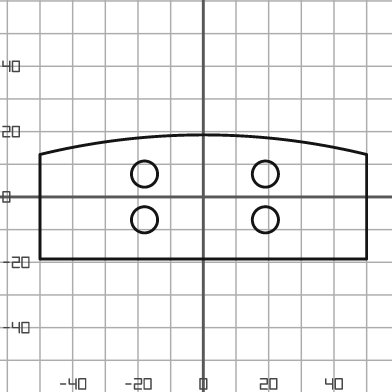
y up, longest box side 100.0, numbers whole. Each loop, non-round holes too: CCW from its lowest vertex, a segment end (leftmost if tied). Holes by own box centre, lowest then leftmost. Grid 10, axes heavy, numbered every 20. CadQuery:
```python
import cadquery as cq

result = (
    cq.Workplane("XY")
    .moveTo(-50.0, -19.0)
    .lineTo(50.0, -19.0)
    .lineTo(50.0, 13.0)
    .threePointArc((0.0, 19.0), (-50.0, 13.0))
    .close()
    .moveTo(-18.0, -7.0)
    .circle(4.0)
    .moveTo(19.0, -7.0)
    .circle(4.0)
    .moveTo(-18.0, 7.0)
    .circle(4.0)
    .moveTo(19.0, 7.0)
    .circle(4.0)
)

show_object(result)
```